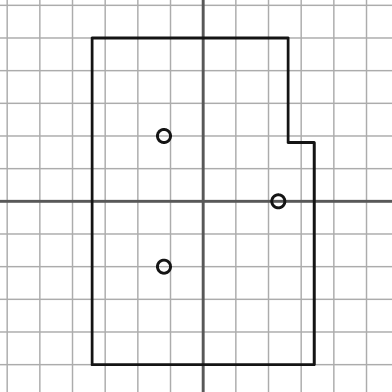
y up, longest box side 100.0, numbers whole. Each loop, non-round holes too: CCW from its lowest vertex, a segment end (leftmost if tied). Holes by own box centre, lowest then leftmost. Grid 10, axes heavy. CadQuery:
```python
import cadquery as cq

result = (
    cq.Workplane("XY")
    .moveTo(-34.0, -50.0)
    .lineTo(34.0, -50.0)
    .lineTo(34.0, 18.0)
    .lineTo(26.0, 18.0)
    .lineTo(26.0, 50.0)
    .lineTo(-34.0, 50.0)
    .close()
    .moveTo(-12.0, -20.0)
    .circle(2.0)
    .moveTo(23.0, 0.0)
    .circle(2.0)
    .moveTo(-12.0, 20.0)
    .circle(2.0)
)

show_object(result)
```